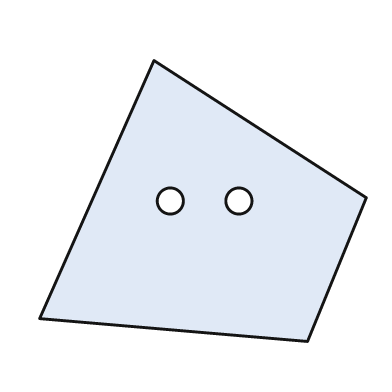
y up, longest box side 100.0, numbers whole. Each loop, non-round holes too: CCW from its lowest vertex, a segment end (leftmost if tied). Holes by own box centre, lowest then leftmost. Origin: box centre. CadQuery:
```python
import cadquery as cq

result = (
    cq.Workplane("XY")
    .moveTo(32.0, -43.0)
    .lineTo(50.0, 1.0)
    .lineTo(-15.0, 43.0)
    .lineTo(-50.0, -36.0)
    .close()
    .moveTo(-10.0, 0.0)
    .circle(4.0)
    .moveTo(11.0, 0.0)
    .circle(4.0)
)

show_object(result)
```